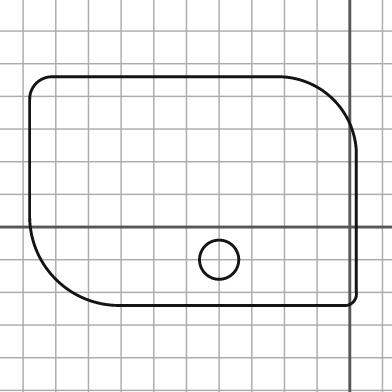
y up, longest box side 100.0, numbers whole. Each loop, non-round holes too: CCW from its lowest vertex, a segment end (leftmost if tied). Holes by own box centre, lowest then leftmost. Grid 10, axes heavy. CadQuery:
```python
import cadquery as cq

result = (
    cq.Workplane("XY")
    .moveTo(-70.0, -24.0)
    .lineTo(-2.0, -24.0)
    .threePointArc((1.0, -23.0), (2.0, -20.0))
    .lineTo(2.0, 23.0)
    .threePointArc((-5.0, 39.0), (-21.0, 46.0))
    .lineTo(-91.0, 46.0)
    .threePointArc((-96.0, 44.0), (-98.0, 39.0))
    .lineTo(-98.0, 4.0)
    .threePointArc((-90.0, -16.0), (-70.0, -24.0))
    .close()
    .moveTo(-40.0, -10.0)
    .circle(6.0)
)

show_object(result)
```